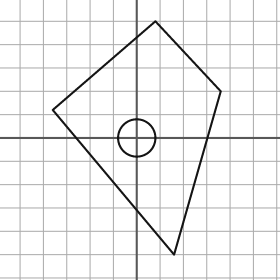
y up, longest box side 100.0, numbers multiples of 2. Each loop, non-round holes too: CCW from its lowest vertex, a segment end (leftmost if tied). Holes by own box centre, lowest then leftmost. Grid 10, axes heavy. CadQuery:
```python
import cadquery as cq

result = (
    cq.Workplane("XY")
    .moveTo(16.0, -50.0)
    .lineTo(36.0, 20.0)
    .lineTo(8.0, 50.0)
    .lineTo(-36.0, 12.0)
    .close()
    .moveTo(0.0, 0.0)
    .circle(8.0)
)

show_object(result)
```